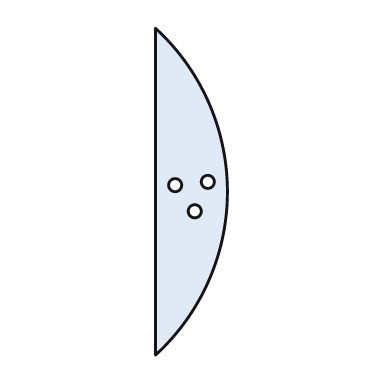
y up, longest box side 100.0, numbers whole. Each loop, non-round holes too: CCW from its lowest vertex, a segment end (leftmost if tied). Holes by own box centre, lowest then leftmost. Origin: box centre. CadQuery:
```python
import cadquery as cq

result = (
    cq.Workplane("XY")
    .moveTo(-11.0, -50.0)
    .threePointArc((11.0, 0.0), (-11.0, 50.0))
    .close()
    .moveTo(1.0, -6.0)
    .circle(2.0)
    .moveTo(-5.0, 2.0)
    .circle(2.0)
    .moveTo(5.0, 3.0)
    .circle(2.0)
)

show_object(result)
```